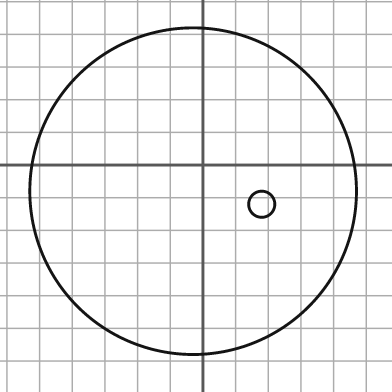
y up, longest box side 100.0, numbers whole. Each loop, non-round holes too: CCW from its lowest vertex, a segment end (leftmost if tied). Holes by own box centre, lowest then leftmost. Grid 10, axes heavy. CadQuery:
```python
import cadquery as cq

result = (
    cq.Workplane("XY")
    .moveTo(-3.0, -8.0)
    .circle(50.0)
    .moveTo(18.0, -12.0)
    .circle(4.0)
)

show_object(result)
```